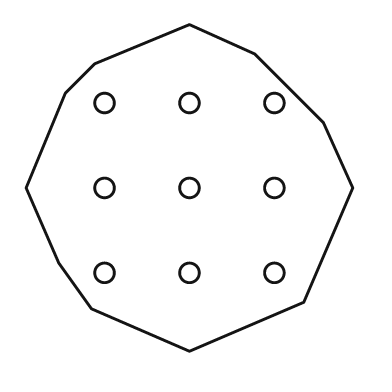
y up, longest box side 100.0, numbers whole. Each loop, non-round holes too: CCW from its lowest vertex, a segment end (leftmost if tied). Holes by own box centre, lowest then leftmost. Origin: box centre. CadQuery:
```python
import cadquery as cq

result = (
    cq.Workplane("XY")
    .moveTo(0.0, -50.0)
    .lineTo(35.0, -35.0)
    .lineTo(50.0, 0.0)
    .lineTo(41.0, 20.0)
    .lineTo(20.0, 41.0)
    .lineTo(0.0, 50.0)
    .lineTo(-29.0, 38.0)
    .lineTo(-38.0, 29.0)
    .lineTo(-50.0, 0.0)
    .lineTo(-40.0, -23.0)
    .lineTo(-30.0, -37.0)
    .close()
    .moveTo(-26.0, -26.0)
    .circle(3.0)
    .moveTo(0.0, -26.0)
    .circle(3.0)
    .moveTo(26.0, -26.0)
    .circle(3.0)
    .moveTo(-26.0, 0.0)
    .circle(3.0)
    .moveTo(0.0, 0.0)
    .circle(3.0)
    .moveTo(26.0, 0.0)
    .circle(3.0)
    .moveTo(-26.0, 26.0)
    .circle(3.0)
    .moveTo(0.0, 26.0)
    .circle(3.0)
    .moveTo(26.0, 26.0)
    .circle(3.0)
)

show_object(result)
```